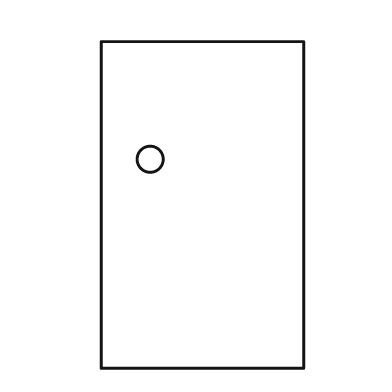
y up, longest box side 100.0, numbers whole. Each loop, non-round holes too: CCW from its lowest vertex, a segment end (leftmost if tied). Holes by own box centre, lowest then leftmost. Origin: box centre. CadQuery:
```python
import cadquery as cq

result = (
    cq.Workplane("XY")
    .moveTo(-31.0, -50.0)
    .lineTo(31.0, -50.0)
    .lineTo(31.0, 50.0)
    .lineTo(-31.0, 50.0)
    .close()
    .moveTo(-16.0, 14.0)
    .circle(4.0)
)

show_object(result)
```